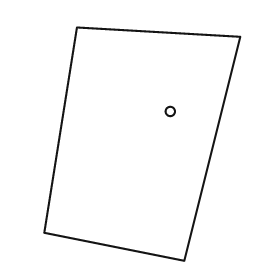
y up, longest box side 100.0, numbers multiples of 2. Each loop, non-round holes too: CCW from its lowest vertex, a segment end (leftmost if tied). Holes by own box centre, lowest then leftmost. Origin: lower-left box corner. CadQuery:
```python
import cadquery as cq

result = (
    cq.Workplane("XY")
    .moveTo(60.0, 0.0)
    .lineTo(84.0, 96.0)
    .lineTo(14.0, 100.0)
    .lineTo(0.0, 12.0)
    .close()
    .moveTo(54.0, 64.0)
    .circle(2.0)
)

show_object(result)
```